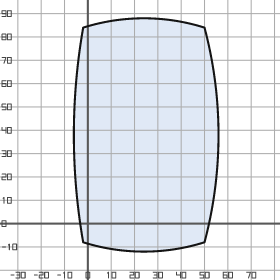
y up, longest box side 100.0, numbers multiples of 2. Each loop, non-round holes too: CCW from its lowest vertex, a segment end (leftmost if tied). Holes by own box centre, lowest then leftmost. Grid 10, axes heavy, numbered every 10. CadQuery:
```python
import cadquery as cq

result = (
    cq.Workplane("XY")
    .moveTo(-2.0, -8.0)
    .threePointArc((24.0, -12.0), (50.0, -8.0))
    .threePointArc((56.0, 38.0), (50.0, 84.0))
    .threePointArc((24.0, 88.0), (-2.0, 84.0))
    .threePointArc((-6.0, 38.0), (-2.0, -8.0))
    .close()
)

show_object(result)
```